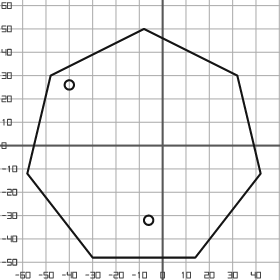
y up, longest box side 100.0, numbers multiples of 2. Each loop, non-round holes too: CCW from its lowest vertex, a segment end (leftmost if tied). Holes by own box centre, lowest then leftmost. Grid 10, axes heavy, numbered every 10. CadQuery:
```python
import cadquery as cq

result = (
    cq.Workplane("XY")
    .moveTo(-30.0, -48.0)
    .lineTo(14.0, -48.0)
    .lineTo(42.0, -12.0)
    .lineTo(32.0, 30.0)
    .lineTo(-8.0, 50.0)
    .lineTo(-48.0, 30.0)
    .lineTo(-58.0, -12.0)
    .close()
    .moveTo(-6.0, -32.0)
    .circle(2.0)
    .moveTo(-40.0, 26.0)
    .circle(2.0)
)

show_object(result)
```